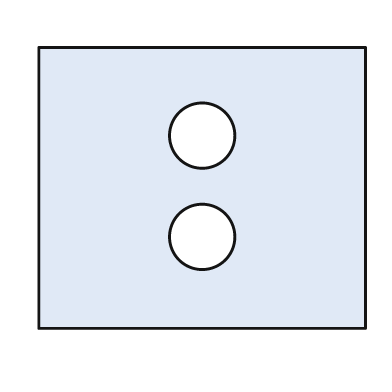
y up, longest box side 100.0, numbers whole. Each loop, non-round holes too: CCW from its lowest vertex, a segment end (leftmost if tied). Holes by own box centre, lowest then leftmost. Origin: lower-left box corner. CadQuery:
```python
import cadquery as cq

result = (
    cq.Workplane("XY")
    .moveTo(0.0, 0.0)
    .lineTo(100.0, 0.0)
    .lineTo(100.0, 86.0)
    .lineTo(0.0, 86.0)
    .close()
    .moveTo(50.0, 28.0)
    .circle(10.0)
    .moveTo(50.0, 59.0)
    .circle(10.0)
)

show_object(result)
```